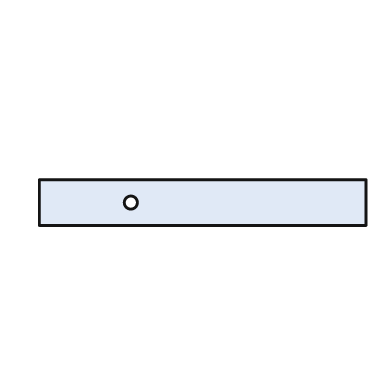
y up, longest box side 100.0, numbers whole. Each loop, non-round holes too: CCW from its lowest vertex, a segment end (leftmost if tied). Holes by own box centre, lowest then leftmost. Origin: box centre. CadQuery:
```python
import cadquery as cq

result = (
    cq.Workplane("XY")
    .moveTo(-50.0, -7.0)
    .lineTo(50.0, -7.0)
    .lineTo(50.0, 7.0)
    .lineTo(-50.0, 7.0)
    .close()
    .moveTo(-22.0, 0.0)
    .circle(2.0)
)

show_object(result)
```